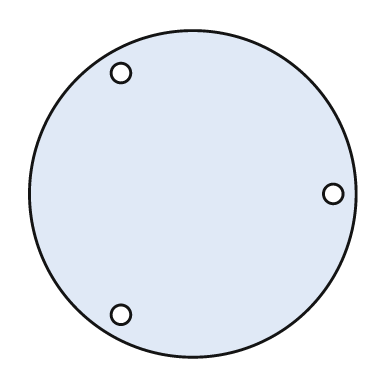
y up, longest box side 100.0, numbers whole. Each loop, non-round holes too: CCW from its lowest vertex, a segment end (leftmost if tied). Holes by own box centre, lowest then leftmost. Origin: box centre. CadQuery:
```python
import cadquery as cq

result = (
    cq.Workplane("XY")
    .moveTo(0.0, 0.0)
    .circle(50.0)
    .moveTo(-22.0, -37.0)
    .circle(3.0)
    .moveTo(43.0, 0.0)
    .circle(3.0)
    .moveTo(-22.0, 37.0)
    .circle(3.0)
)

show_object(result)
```